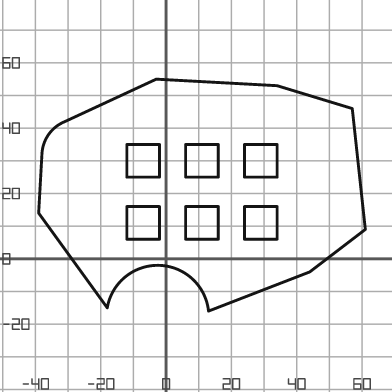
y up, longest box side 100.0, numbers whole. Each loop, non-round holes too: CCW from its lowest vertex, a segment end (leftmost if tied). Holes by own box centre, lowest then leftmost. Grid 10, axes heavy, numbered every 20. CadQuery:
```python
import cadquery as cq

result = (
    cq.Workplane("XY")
    .moveTo(13.0, -16.0)
    .lineTo(44.0, -4.0)
    .lineTo(61.0, 9.0)
    .lineTo(57.0, 46.0)
    .lineTo(34.0, 53.0)
    .lineTo(-3.0, 55.0)
    .lineTo(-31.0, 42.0)
    .threePointArc((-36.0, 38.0), (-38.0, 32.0))
    .lineTo(-39.0, 14.0)
    .lineTo(-18.0, -15.0)
    .threePointArc((-2.0, -2.0), (13.0, -16.0))
    .close()
    .moveTo(-12.0, 6.0)
    .lineTo(-2.0, 6.0)
    .lineTo(-2.0, 16.0)
    .lineTo(-12.0, 16.0)
    .close()
    .moveTo(6.0, 6.0)
    .lineTo(16.0, 6.0)
    .lineTo(16.0, 16.0)
    .lineTo(6.0, 16.0)
    .close()
    .moveTo(24.0, 6.0)
    .lineTo(34.0, 6.0)
    .lineTo(34.0, 16.0)
    .lineTo(24.0, 16.0)
    .close()
    .moveTo(-12.0, 25.0)
    .lineTo(-2.0, 25.0)
    .lineTo(-2.0, 35.0)
    .lineTo(-12.0, 35.0)
    .close()
    .moveTo(6.0, 25.0)
    .lineTo(16.0, 25.0)
    .lineTo(16.0, 35.0)
    .lineTo(6.0, 35.0)
    .close()
    .moveTo(24.0, 25.0)
    .lineTo(34.0, 25.0)
    .lineTo(34.0, 35.0)
    .lineTo(24.0, 35.0)
    .close()
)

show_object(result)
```